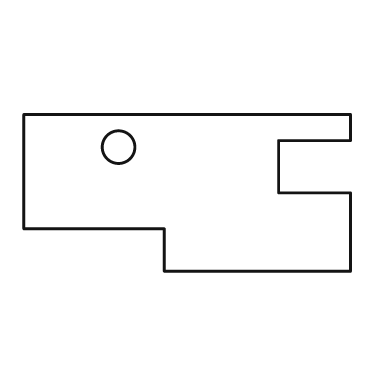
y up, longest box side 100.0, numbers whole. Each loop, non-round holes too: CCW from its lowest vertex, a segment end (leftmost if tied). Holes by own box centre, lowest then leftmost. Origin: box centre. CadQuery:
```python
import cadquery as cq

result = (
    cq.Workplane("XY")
    .moveTo(-7.0, -24.0)
    .lineTo(50.0, -24.0)
    .lineTo(50.0, 0.0)
    .lineTo(28.0, 0.0)
    .lineTo(28.0, 16.0)
    .lineTo(50.0, 16.0)
    .lineTo(50.0, 24.0)
    .lineTo(-50.0, 24.0)
    .lineTo(-50.0, -11.0)
    .lineTo(-7.0, -11.0)
    .close()
    .moveTo(-21.0, 14.0)
    .circle(5.0)
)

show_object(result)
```